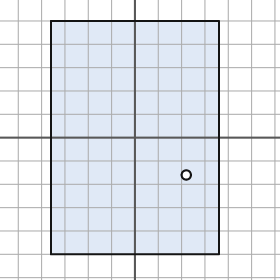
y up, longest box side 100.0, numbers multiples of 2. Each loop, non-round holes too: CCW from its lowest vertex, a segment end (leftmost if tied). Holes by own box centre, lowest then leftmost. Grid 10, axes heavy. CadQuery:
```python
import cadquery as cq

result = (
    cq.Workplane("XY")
    .moveTo(-36.0, -50.0)
    .lineTo(36.0, -50.0)
    .lineTo(36.0, 50.0)
    .lineTo(-36.0, 50.0)
    .close()
    .moveTo(22.0, -16.0)
    .circle(2.0)
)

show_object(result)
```